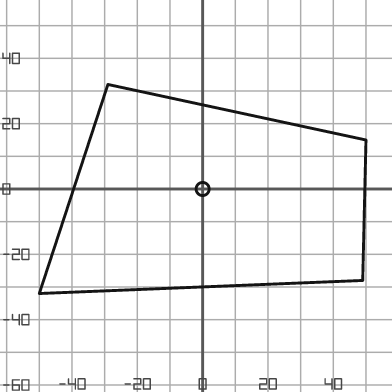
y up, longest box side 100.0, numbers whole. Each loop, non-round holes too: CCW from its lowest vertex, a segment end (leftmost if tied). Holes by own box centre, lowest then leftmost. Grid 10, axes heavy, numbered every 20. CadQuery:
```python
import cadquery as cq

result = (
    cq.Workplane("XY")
    .moveTo(-50.0, -32.0)
    .lineTo(49.0, -28.0)
    .lineTo(50.0, 15.0)
    .lineTo(-29.0, 32.0)
    .close()
    .moveTo(0.0, 0.0)
    .circle(2.0)
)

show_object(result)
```